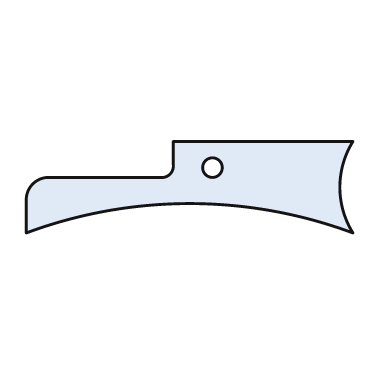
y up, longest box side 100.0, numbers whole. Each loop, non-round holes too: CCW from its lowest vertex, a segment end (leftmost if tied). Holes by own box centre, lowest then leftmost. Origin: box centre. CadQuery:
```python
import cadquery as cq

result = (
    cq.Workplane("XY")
    .moveTo(-50.0, -14.0)
    .threePointArc((0.0, -5.0), (50.0, -14.0))
    .threePointArc((46.0, 0.0), (50.0, 14.0))
    .lineTo(-5.0, 14.0)
    .lineTo(-5.0, 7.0)
    .threePointArc((-6.0, 4.0), (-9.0, 3.0))
    .lineTo(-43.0, 3.0)
    .threePointArc((-48.0, 1.0), (-50.0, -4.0))
    .close()
    .moveTo(7.0, 6.0)
    .circle(3.0)
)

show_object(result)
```